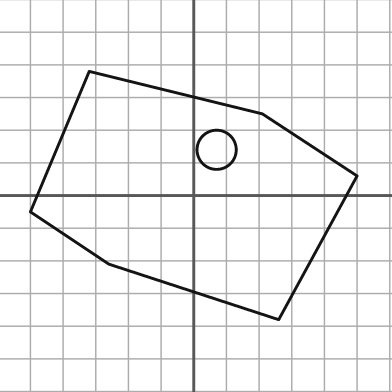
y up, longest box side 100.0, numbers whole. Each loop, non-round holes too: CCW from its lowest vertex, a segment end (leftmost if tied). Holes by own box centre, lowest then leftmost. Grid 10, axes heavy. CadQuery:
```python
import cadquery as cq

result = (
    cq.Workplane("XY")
    .moveTo(26.0, -38.0)
    .lineTo(50.0, 6.0)
    .lineTo(21.0, 25.0)
    .lineTo(-32.0, 38.0)
    .lineTo(-50.0, -5.0)
    .lineTo(-26.0, -21.0)
    .close()
    .moveTo(7.0, 14.0)
    .circle(6.0)
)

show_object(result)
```